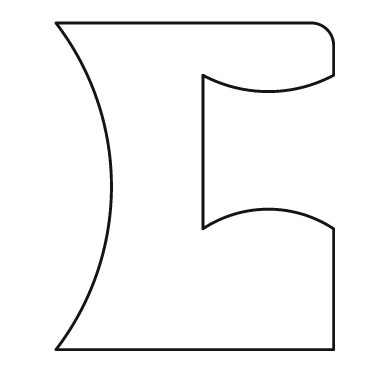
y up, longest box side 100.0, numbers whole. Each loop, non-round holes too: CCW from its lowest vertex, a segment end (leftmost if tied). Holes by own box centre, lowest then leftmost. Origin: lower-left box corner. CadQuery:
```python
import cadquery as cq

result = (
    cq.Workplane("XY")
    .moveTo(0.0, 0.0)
    .lineTo(85.0, 0.0)
    .lineTo(85.0, 37.0)
    .threePointArc((65.0, 43.0), (45.0, 37.0))
    .lineTo(45.0, 84.0)
    .threePointArc((65.0, 79.0), (85.0, 84.0))
    .lineTo(85.0, 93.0)
    .threePointArc((83.0, 98.0), (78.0, 100.0))
    .lineTo(0.0, 100.0)
    .threePointArc((17.0, 50.0), (0.0, 0.0))
    .close()
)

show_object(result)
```